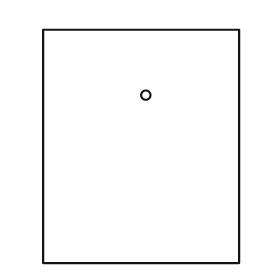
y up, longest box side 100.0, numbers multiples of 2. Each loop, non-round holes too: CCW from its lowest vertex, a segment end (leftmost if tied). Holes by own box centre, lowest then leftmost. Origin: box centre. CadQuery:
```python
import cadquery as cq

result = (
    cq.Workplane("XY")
    .moveTo(-42.0, -50.0)
    .lineTo(42.0, -50.0)
    .lineTo(42.0, 50.0)
    .lineTo(-42.0, 50.0)
    .close()
    .moveTo(2.0, 22.0)
    .circle(2.0)
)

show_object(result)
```